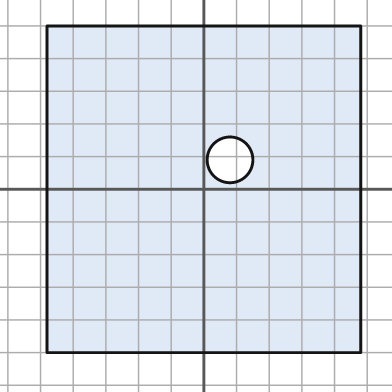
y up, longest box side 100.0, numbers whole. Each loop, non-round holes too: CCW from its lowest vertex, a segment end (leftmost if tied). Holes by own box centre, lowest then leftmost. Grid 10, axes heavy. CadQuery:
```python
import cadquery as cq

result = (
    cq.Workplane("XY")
    .moveTo(-48.0, -50.0)
    .lineTo(48.0, -50.0)
    .lineTo(48.0, 50.0)
    .lineTo(-48.0, 50.0)
    .close()
    .moveTo(8.0, 9.0)
    .circle(7.0)
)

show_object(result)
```